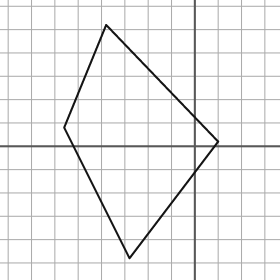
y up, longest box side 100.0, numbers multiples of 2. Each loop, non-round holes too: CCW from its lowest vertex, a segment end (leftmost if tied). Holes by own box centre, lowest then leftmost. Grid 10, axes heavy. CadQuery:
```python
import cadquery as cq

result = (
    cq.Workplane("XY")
    .moveTo(-28.0, -48.0)
    .lineTo(10.0, 2.0)
    .lineTo(-38.0, 52.0)
    .lineTo(-56.0, 8.0)
    .close()
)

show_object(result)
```